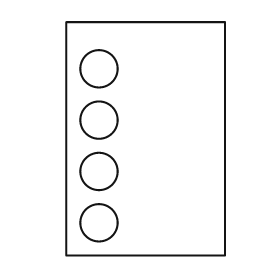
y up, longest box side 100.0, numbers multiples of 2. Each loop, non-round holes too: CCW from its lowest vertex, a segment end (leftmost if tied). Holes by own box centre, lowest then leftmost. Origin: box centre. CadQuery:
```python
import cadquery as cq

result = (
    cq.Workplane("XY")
    .moveTo(-34.0, -50.0)
    .lineTo(34.0, -50.0)
    .lineTo(34.0, 50.0)
    .lineTo(-34.0, 50.0)
    .close()
    .moveTo(-20.0, -36.0)
    .circle(8.0)
    .moveTo(-20.0, -14.0)
    .circle(8.0)
    .moveTo(-20.0, 8.0)
    .circle(8.0)
    .moveTo(-20.0, 30.0)
    .circle(8.0)
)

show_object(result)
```